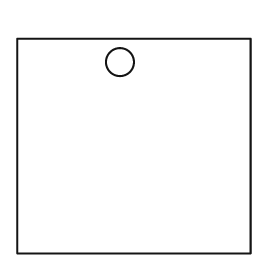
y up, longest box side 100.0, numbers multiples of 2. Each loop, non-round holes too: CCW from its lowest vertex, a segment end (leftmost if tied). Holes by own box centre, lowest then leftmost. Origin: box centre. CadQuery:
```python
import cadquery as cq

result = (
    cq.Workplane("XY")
    .moveTo(-50.0, -46.0)
    .lineTo(50.0, -46.0)
    .lineTo(50.0, 46.0)
    .lineTo(-50.0, 46.0)
    .close()
    .moveTo(-6.0, 36.0)
    .circle(6.0)
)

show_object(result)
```